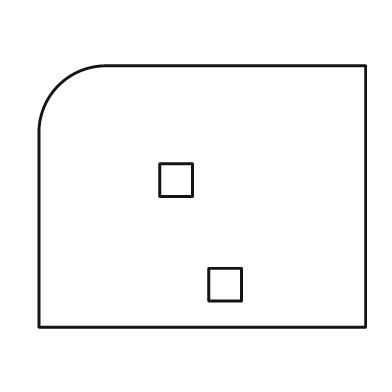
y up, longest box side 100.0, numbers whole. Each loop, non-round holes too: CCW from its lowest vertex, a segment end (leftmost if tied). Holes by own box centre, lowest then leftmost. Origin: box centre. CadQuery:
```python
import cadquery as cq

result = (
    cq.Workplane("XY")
    .moveTo(-50.0, -40.0)
    .lineTo(50.0, -40.0)
    .lineTo(50.0, 40.0)
    .lineTo(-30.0, 40.0)
    .threePointArc((-44.0, 34.0), (-50.0, 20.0))
    .close()
    .moveTo(2.0, -32.0)
    .lineTo(12.0, -32.0)
    .lineTo(12.0, -22.0)
    .lineTo(2.0, -22.0)
    .close()
    .moveTo(-13.0, 0.0)
    .lineTo(-3.0, 0.0)
    .lineTo(-3.0, 10.0)
    .lineTo(-13.0, 10.0)
    .close()
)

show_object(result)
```